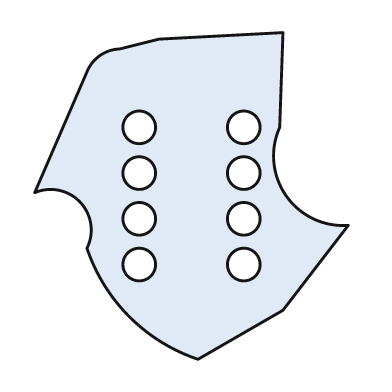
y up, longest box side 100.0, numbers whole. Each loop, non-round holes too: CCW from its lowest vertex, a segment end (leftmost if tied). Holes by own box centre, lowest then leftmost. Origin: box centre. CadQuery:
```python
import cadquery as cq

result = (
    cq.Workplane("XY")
    .moveTo(2.0, -50.0)
    .lineTo(28.0, -35.0)
    .lineTo(48.0, -9.0)
    .threePointArc((29.0, 0.0), (27.0, 21.0))
    .lineTo(28.0, 50.0)
    .lineTo(-10.0, 48.0)
    .lineTo(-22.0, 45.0)
    .threePointArc((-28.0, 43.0), (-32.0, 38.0))
    .lineTo(-48.0, 1.0)
    .threePointArc((-34.0, -2.0), (-32.0, -16.0))
    .threePointArc((-19.0, -37.0), (2.0, -50.0))
    .close()
    .moveTo(-16.0, -21.0)
    .circle(5.0)
    .moveTo(16.0, -21.0)
    .circle(5.0)
    .moveTo(-16.0, -7.0)
    .circle(5.0)
    .moveTo(16.0, -7.0)
    .circle(5.0)
    .moveTo(-16.0, 7.0)
    .circle(5.0)
    .moveTo(16.0, 7.0)
    .circle(5.0)
    .moveTo(-16.0, 21.0)
    .circle(5.0)
    .moveTo(16.0, 21.0)
    .circle(5.0)
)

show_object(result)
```